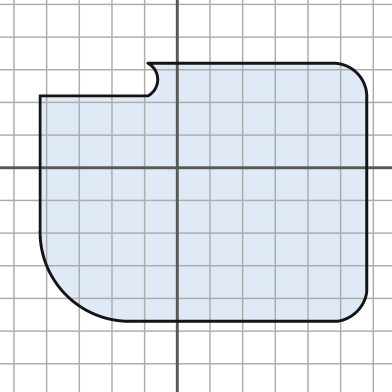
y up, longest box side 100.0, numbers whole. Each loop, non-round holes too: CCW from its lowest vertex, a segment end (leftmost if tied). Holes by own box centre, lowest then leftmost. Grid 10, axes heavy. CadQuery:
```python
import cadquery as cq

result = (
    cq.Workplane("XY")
    .moveTo(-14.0, -47.0)
    .lineTo(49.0, -47.0)
    .threePointArc((55.0, -44.0), (58.0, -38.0))
    .lineTo(58.0, 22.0)
    .threePointArc((55.0, 29.0), (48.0, 32.0))
    .lineTo(-9.0, 32.0)
    .threePointArc((-6.0, 27.0), (-9.0, 22.0))
    .lineTo(-42.0, 22.0)
    .lineTo(-42.0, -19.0)
    .threePointArc((-34.0, -39.0), (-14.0, -47.0))
    .close()
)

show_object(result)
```